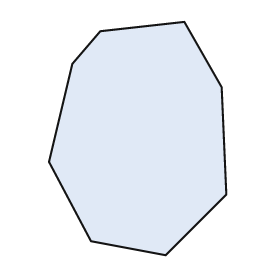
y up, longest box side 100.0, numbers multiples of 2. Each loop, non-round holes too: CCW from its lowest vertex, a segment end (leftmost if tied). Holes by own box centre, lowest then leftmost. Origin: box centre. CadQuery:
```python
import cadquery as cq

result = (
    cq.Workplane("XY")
    .moveTo(12.0, -50.0)
    .lineTo(38.0, -24.0)
    .lineTo(36.0, 22.0)
    .lineTo(20.0, 50.0)
    .lineTo(-16.0, 46.0)
    .lineTo(-28.0, 32.0)
    .lineTo(-38.0, -10.0)
    .lineTo(-20.0, -44.0)
    .close()
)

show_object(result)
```